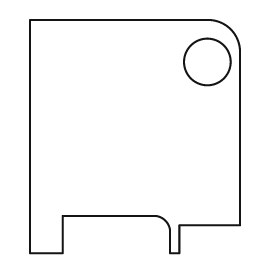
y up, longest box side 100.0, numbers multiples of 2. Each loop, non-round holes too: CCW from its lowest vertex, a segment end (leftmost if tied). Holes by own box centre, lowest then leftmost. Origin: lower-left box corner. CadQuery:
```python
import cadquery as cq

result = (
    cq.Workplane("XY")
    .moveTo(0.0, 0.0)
    .lineTo(14.0, 0.0)
    .lineTo(14.0, 16.0)
    .lineTo(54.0, 16.0)
    .threePointArc((58.0, 14.0), (60.0, 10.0))
    .lineTo(60.0, 0.0)
    .lineTo(64.0, 0.0)
    .lineTo(64.0, 12.0)
    .lineTo(90.0, 12.0)
    .lineTo(90.0, 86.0)
    .threePointArc((86.0, 96.0), (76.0, 100.0))
    .lineTo(0.0, 100.0)
    .close()
    .moveTo(76.0, 82.0)
    .circle(10.0)
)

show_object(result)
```